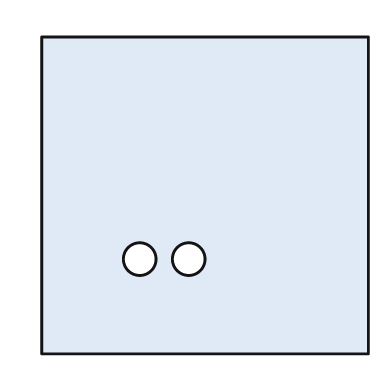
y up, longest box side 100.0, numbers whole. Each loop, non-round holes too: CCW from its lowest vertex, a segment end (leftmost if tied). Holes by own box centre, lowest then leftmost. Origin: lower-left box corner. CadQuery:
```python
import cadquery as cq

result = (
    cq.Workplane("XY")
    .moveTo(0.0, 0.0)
    .lineTo(100.0, 0.0)
    .lineTo(100.0, 97.0)
    .lineTo(0.0, 97.0)
    .close()
    .moveTo(30.0, 29.0)
    .circle(5.0)
    .moveTo(45.0, 29.0)
    .circle(5.0)
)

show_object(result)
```